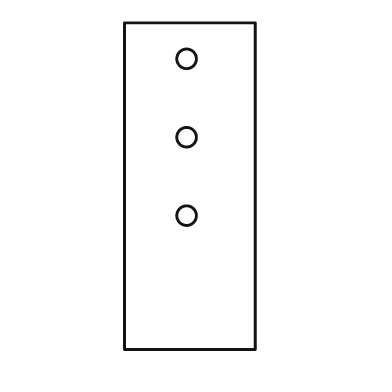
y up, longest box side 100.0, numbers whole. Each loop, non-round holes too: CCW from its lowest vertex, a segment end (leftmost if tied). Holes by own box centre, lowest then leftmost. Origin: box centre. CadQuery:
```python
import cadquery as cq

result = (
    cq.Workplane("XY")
    .moveTo(-20.0, -50.0)
    .lineTo(20.0, -50.0)
    .lineTo(20.0, 50.0)
    .lineTo(-20.0, 50.0)
    .close()
    .moveTo(-1.0, -9.0)
    .circle(3.0)
    .moveTo(-1.0, 15.0)
    .circle(3.0)
    .moveTo(-1.0, 39.0)
    .circle(3.0)
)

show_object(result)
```